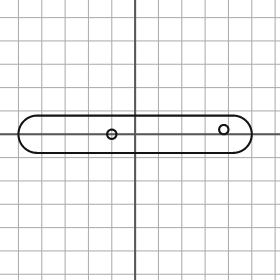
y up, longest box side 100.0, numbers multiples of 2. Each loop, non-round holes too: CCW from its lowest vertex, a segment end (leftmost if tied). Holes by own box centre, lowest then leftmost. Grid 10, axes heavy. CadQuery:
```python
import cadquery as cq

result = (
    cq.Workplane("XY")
    .moveTo(-42.0, -8.0)
    .lineTo(42.0, -8.0)
    .threePointArc((50.0, 0.0), (42.0, 8.0))
    .lineTo(-42.0, 8.0)
    .threePointArc((-50.0, 0.0), (-42.0, -8.0))
    .close()
    .moveTo(-10.0, 0.0)
    .circle(2.0)
    .moveTo(38.0, 2.0)
    .circle(2.0)
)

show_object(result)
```